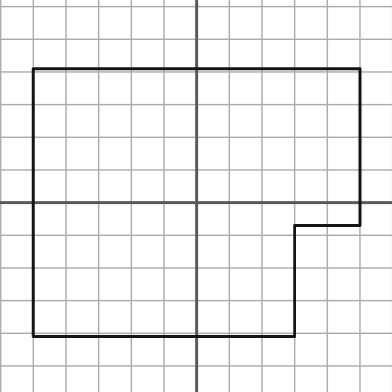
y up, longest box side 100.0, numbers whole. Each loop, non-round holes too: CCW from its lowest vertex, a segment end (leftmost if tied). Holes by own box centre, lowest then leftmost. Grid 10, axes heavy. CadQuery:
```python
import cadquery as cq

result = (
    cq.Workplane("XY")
    .moveTo(-50.0, -41.0)
    .lineTo(30.0, -41.0)
    .lineTo(30.0, -7.0)
    .lineTo(50.0, -7.0)
    .lineTo(50.0, 41.0)
    .lineTo(-50.0, 41.0)
    .close()
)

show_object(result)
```